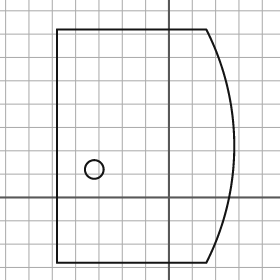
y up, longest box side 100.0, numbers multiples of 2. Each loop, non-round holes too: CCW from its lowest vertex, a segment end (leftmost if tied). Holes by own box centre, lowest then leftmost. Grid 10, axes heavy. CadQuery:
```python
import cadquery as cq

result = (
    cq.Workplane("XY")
    .moveTo(-48.0, -28.0)
    .lineTo(16.0, -28.0)
    .threePointArc((28.0, 22.0), (16.0, 72.0))
    .lineTo(-48.0, 72.0)
    .close()
    .moveTo(-32.0, 12.0)
    .circle(4.0)
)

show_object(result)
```